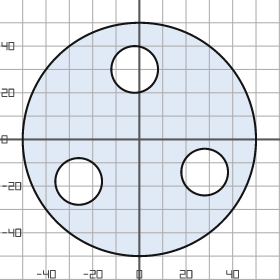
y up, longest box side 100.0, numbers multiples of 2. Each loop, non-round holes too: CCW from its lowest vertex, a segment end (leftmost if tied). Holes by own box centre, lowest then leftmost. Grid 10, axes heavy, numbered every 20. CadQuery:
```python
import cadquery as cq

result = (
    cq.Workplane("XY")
    .moveTo(0.0, 0.0)
    .circle(50.0)
    .moveTo(-26.0, -18.0)
    .circle(10.0)
    .moveTo(28.0, -14.0)
    .circle(10.0)
    .moveTo(-2.0, 30.0)
    .circle(10.0)
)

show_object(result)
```